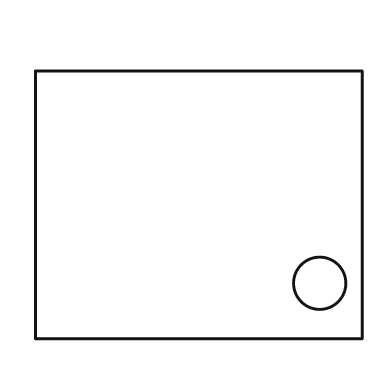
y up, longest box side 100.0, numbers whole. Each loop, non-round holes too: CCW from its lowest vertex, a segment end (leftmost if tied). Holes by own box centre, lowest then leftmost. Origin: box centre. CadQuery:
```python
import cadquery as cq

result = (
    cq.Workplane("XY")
    .moveTo(-50.0, -41.0)
    .lineTo(50.0, -41.0)
    .lineTo(50.0, 41.0)
    .lineTo(-50.0, 41.0)
    .close()
    .moveTo(37.0, -24.0)
    .circle(8.0)
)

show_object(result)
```